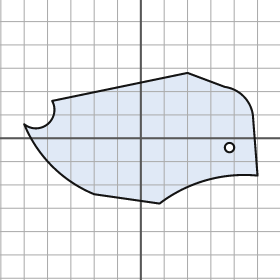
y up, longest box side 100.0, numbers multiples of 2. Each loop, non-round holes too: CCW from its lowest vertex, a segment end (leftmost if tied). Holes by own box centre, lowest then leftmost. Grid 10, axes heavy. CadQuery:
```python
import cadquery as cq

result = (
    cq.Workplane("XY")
    .moveTo(8.0, -28.0)
    .threePointArc((28.0, -18.0), (50.0, -16.0))
    .lineTo(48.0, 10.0)
    .threePointArc((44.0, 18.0), (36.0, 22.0))
    .lineTo(20.0, 28.0)
    .lineTo(-38.0, 16.0)
    .threePointArc((-40.0, 6.0), (-50.0, 6.0))
    .threePointArc((-38.0, -12.0), (-20.0, -24.0))
    .close()
    .moveTo(38.0, -4.0)
    .circle(2.0)
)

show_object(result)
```